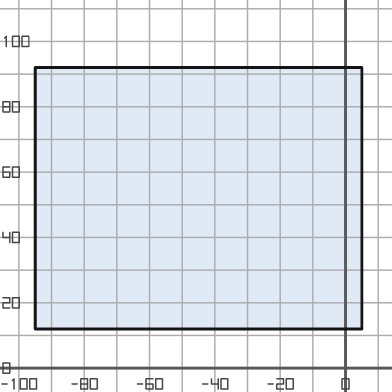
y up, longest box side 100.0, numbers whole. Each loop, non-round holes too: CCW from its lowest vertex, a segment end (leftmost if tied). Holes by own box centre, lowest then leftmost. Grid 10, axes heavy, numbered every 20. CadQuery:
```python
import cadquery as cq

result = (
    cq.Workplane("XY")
    .moveTo(-95.0, 12.0)
    .lineTo(5.0, 12.0)
    .lineTo(5.0, 92.0)
    .lineTo(-95.0, 92.0)
    .close()
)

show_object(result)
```